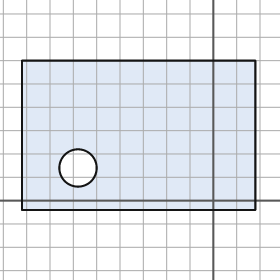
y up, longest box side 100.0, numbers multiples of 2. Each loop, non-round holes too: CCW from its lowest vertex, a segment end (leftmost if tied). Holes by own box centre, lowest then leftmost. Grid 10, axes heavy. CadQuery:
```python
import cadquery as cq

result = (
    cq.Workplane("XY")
    .moveTo(-82.0, -4.0)
    .lineTo(18.0, -4.0)
    .lineTo(18.0, 60.0)
    .lineTo(-82.0, 60.0)
    .close()
    .moveTo(-58.0, 14.0)
    .circle(8.0)
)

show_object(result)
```